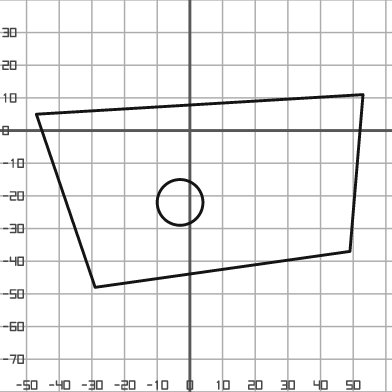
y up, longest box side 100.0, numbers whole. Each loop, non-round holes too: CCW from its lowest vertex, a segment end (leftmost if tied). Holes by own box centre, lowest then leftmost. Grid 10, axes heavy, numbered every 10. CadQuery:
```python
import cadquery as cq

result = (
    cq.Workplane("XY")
    .moveTo(-29.0, -48.0)
    .lineTo(49.0, -37.0)
    .lineTo(53.0, 11.0)
    .lineTo(-47.0, 5.0)
    .close()
    .moveTo(-3.0, -22.0)
    .circle(7.0)
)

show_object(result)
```